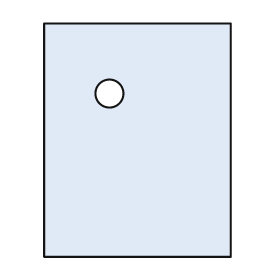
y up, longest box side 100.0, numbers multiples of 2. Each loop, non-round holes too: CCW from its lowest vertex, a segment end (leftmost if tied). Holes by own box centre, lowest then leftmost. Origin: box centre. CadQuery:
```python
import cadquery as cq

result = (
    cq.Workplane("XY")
    .moveTo(-40.0, -50.0)
    .lineTo(40.0, -50.0)
    .lineTo(40.0, 50.0)
    .lineTo(-40.0, 50.0)
    .close()
    .moveTo(-12.0, 20.0)
    .circle(6.0)
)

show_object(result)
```